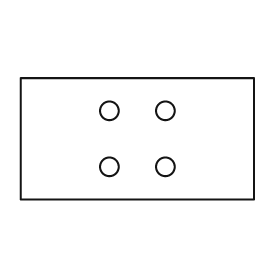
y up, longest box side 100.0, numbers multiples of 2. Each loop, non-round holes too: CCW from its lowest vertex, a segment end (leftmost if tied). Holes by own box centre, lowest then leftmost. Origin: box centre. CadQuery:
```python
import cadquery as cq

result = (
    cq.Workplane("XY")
    .moveTo(-50.0, -26.0)
    .lineTo(50.0, -26.0)
    .lineTo(50.0, 26.0)
    .lineTo(-50.0, 26.0)
    .close()
    .moveTo(-12.0, -12.0)
    .circle(4.0)
    .moveTo(12.0, -12.0)
    .circle(4.0)
    .moveTo(-12.0, 12.0)
    .circle(4.0)
    .moveTo(12.0, 12.0)
    .circle(4.0)
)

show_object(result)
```